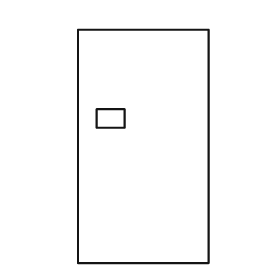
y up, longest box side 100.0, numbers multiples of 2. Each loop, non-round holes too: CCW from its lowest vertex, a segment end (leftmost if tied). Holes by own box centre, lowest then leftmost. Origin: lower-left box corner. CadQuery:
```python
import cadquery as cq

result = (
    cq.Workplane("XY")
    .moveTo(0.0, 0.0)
    .lineTo(56.0, 0.0)
    .lineTo(56.0, 100.0)
    .lineTo(0.0, 100.0)
    .close()
    .moveTo(8.0, 58.0)
    .lineTo(20.0, 58.0)
    .lineTo(20.0, 66.0)
    .lineTo(8.0, 66.0)
    .close()
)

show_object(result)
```